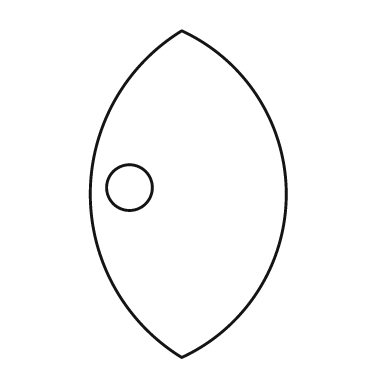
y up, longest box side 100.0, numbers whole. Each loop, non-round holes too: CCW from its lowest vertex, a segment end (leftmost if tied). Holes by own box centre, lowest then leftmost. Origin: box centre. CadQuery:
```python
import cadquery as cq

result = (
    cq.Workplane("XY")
    .moveTo(-2.0, -50.0)
    .threePointArc((30.0, 0.0), (-2.0, 50.0))
    .threePointArc((-30.0, 0.0), (-2.0, -50.0))
    .close()
    .moveTo(-18.0, 2.0)
    .circle(7.0)
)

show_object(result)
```